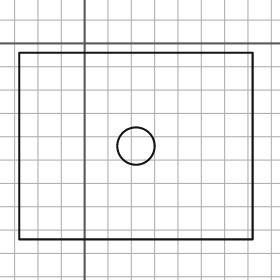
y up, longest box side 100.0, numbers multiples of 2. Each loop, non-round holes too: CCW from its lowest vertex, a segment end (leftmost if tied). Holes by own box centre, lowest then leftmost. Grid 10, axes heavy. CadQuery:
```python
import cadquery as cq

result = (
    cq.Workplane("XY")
    .moveTo(-28.0, -84.0)
    .lineTo(72.0, -84.0)
    .lineTo(72.0, -4.0)
    .lineTo(-28.0, -4.0)
    .close()
    .moveTo(22.0, -44.0)
    .circle(8.0)
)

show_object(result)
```